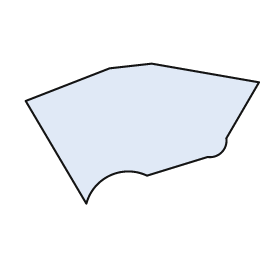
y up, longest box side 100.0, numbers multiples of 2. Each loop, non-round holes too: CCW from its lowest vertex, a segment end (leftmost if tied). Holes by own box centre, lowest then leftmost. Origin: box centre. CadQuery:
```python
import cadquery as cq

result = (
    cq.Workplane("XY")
    .moveTo(-24.0, -30.0)
    .threePointArc((-14.0, -18.0), (2.0, -18.0))
    .lineTo(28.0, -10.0)
    .threePointArc((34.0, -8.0), (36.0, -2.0))
    .lineTo(50.0, 22.0)
    .lineTo(4.0, 30.0)
    .lineTo(-14.0, 28.0)
    .lineTo(-50.0, 14.0)
    .close()
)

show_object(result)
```